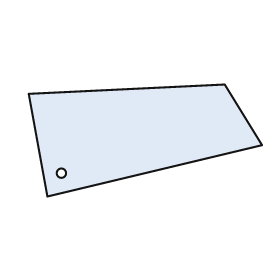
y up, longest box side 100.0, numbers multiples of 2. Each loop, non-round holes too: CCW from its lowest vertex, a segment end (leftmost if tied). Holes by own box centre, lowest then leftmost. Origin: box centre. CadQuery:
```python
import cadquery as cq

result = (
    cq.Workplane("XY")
    .moveTo(-42.0, -24.0)
    .lineTo(50.0, -2.0)
    .lineTo(34.0, 24.0)
    .lineTo(-50.0, 20.0)
    .close()
    .moveTo(-36.0, -14.0)
    .circle(2.0)
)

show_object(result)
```